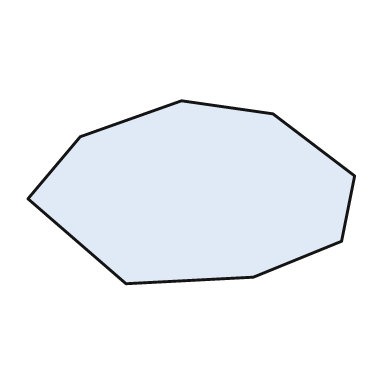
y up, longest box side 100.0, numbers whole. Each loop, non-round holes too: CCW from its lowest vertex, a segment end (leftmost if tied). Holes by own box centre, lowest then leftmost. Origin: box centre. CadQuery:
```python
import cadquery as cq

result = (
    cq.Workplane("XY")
    .moveTo(-20.0, -28.0)
    .lineTo(19.0, -26.0)
    .lineTo(46.0, -15.0)
    .lineTo(50.0, 5.0)
    .lineTo(25.0, 24.0)
    .lineTo(-3.0, 28.0)
    .lineTo(-34.0, 17.0)
    .lineTo(-50.0, -2.0)
    .close()
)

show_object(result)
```